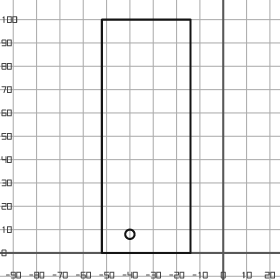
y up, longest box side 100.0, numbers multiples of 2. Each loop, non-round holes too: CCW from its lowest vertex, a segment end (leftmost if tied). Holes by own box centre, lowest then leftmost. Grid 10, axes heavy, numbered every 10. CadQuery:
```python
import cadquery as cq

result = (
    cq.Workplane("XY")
    .moveTo(-52.0, 0.0)
    .lineTo(-14.0, 0.0)
    .lineTo(-14.0, 100.0)
    .lineTo(-52.0, 100.0)
    .close()
    .moveTo(-40.0, 8.0)
    .circle(2.0)
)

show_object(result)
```